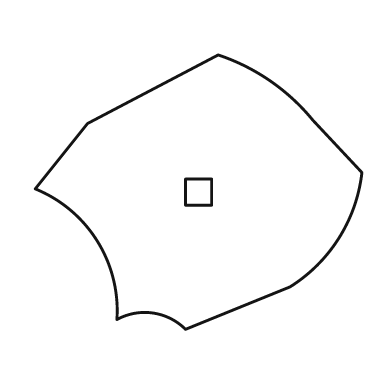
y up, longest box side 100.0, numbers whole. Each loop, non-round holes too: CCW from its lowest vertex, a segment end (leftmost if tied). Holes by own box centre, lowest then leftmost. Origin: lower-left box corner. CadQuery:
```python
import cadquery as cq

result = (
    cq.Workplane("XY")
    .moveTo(46.0, 0.0)
    .lineTo(78.0, 13.0)
    .threePointArc((93.0, 28.0), (100.0, 48.0))
    .lineTo(85.0, 64.0)
    .threePointArc((72.0, 76.0), (56.0, 84.0))
    .lineTo(16.0, 63.0)
    .lineTo(0.0, 43.0)
    .threePointArc((19.0, 27.0), (25.0, 3.0))
    .threePointArc((36.0, 5.0), (46.0, 0.0))
    .close()
    .moveTo(46.0, 38.0)
    .lineTo(54.0, 38.0)
    .lineTo(54.0, 46.0)
    .lineTo(46.0, 46.0)
    .close()
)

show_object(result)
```